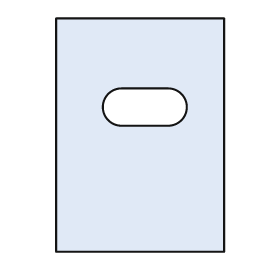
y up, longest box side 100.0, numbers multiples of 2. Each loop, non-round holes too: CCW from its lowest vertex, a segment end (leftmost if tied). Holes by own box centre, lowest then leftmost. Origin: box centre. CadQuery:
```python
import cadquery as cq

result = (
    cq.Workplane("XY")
    .moveTo(-36.0, -50.0)
    .lineTo(36.0, -50.0)
    .lineTo(36.0, 50.0)
    .lineTo(-36.0, 50.0)
    .close()
    .moveTo(-8.0, 4.0)
    .lineTo(12.0, 4.0)
    .threePointArc((20.0, 12.0), (12.0, 20.0))
    .lineTo(-8.0, 20.0)
    .threePointArc((-16.0, 12.0), (-8.0, 4.0))
    .close()
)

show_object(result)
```